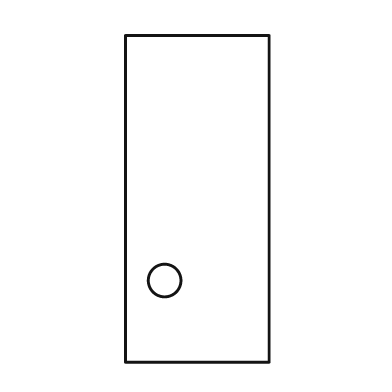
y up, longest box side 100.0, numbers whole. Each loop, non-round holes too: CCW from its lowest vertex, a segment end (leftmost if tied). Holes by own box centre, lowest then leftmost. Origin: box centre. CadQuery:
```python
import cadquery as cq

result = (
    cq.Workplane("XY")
    .moveTo(-22.0, -50.0)
    .lineTo(22.0, -50.0)
    .lineTo(22.0, 50.0)
    .lineTo(-22.0, 50.0)
    .close()
    .moveTo(-10.0, -25.0)
    .circle(5.0)
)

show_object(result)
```